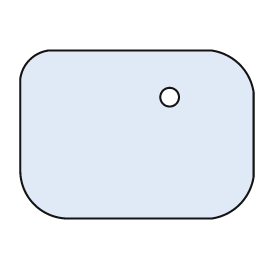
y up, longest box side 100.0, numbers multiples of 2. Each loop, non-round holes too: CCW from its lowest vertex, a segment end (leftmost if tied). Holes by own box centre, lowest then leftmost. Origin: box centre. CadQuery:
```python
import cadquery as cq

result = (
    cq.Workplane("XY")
    .moveTo(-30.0, -36.0)
    .lineTo(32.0, -36.0)
    .threePointArc((44.0, -30.0), (50.0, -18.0))
    .lineTo(50.0, 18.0)
    .threePointArc((44.0, 30.0), (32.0, 36.0))
    .lineTo(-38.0, 36.0)
    .threePointArc((-46.0, 32.0), (-50.0, 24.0))
    .lineTo(-50.0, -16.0)
    .threePointArc((-44.0, -30.0), (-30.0, -36.0))
    .close()
    .moveTo(14.0, 16.0)
    .circle(4.0)
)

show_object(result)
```